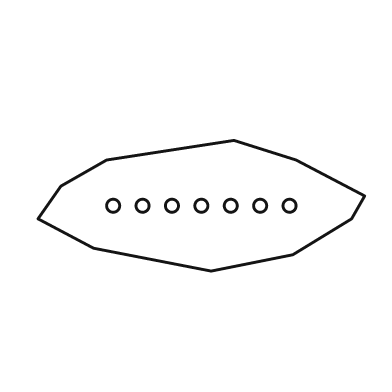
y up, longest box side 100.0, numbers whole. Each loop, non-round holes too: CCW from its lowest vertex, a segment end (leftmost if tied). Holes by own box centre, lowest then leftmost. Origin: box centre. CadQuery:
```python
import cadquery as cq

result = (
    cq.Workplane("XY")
    .moveTo(3.0, -20.0)
    .lineTo(28.0, -15.0)
    .lineTo(46.0, -4.0)
    .lineTo(50.0, 3.0)
    .lineTo(29.0, 14.0)
    .lineTo(10.0, 20.0)
    .lineTo(-29.0, 14.0)
    .lineTo(-43.0, 6.0)
    .lineTo(-50.0, -4.0)
    .lineTo(-33.0, -13.0)
    .close()
    .moveTo(-27.0, 0.0)
    .circle(2.0)
    .moveTo(-18.0, 0.0)
    .circle(2.0)
    .moveTo(-9.0, 0.0)
    .circle(2.0)
    .moveTo(0.0, 0.0)
    .circle(2.0)
    .moveTo(9.0, 0.0)
    .circle(2.0)
    .moveTo(18.0, 0.0)
    .circle(2.0)
    .moveTo(27.0, 0.0)
    .circle(2.0)
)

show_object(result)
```